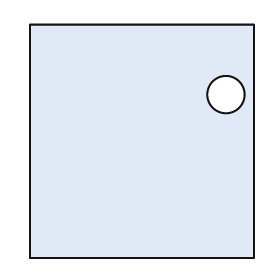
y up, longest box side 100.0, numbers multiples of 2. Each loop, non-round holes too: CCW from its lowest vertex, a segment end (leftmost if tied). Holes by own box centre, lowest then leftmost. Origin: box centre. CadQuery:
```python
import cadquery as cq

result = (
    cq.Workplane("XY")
    .moveTo(-48.0, -50.0)
    .lineTo(48.0, -50.0)
    .lineTo(48.0, 50.0)
    .lineTo(-48.0, 50.0)
    .close()
    .moveTo(36.0, 20.0)
    .circle(8.0)
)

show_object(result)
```